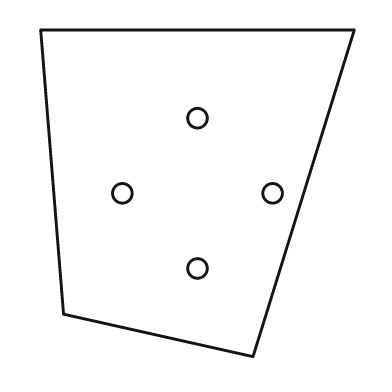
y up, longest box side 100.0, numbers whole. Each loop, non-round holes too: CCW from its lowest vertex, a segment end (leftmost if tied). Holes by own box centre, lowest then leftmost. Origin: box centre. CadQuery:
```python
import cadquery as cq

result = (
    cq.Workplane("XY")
    .moveTo(17.0, -50.0)
    .lineTo(48.0, 50.0)
    .lineTo(-48.0, 50.0)
    .lineTo(-41.0, -37.0)
    .close()
    .moveTo(0.0, -23.0)
    .circle(3.0)
    .moveTo(-23.0, 0.0)
    .circle(3.0)
    .moveTo(23.0, 0.0)
    .circle(3.0)
    .moveTo(0.0, 23.0)
    .circle(3.0)
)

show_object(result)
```